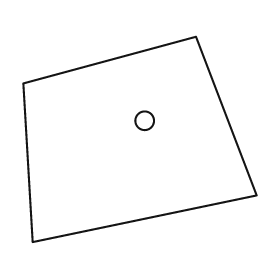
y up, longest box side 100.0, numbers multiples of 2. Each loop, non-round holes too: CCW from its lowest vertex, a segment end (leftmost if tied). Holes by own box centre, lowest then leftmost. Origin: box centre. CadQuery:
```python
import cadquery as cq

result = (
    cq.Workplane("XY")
    .moveTo(-46.0, -44.0)
    .lineTo(50.0, -24.0)
    .lineTo(24.0, 44.0)
    .lineTo(-50.0, 24.0)
    .close()
    .moveTo(2.0, 8.0)
    .circle(4.0)
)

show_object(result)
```